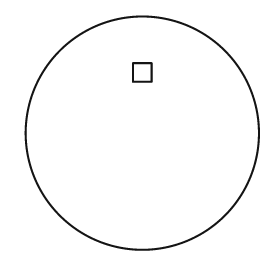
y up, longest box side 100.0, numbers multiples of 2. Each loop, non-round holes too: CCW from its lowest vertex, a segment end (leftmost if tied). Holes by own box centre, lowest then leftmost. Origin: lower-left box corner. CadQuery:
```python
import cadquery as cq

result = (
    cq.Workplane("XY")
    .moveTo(50.0, 50.0)
    .circle(50.0)
    .moveTo(46.0, 72.0)
    .lineTo(54.0, 72.0)
    .lineTo(54.0, 80.0)
    .lineTo(46.0, 80.0)
    .close()
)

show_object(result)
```